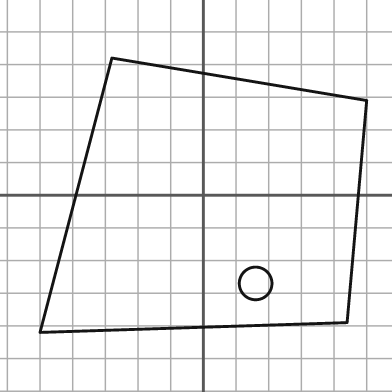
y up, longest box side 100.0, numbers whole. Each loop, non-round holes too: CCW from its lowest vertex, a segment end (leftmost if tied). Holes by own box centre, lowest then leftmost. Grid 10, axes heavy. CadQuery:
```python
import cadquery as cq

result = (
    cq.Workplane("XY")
    .moveTo(-50.0, -42.0)
    .lineTo(44.0, -39.0)
    .lineTo(50.0, 29.0)
    .lineTo(-28.0, 42.0)
    .close()
    .moveTo(16.0, -27.0)
    .circle(5.0)
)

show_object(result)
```